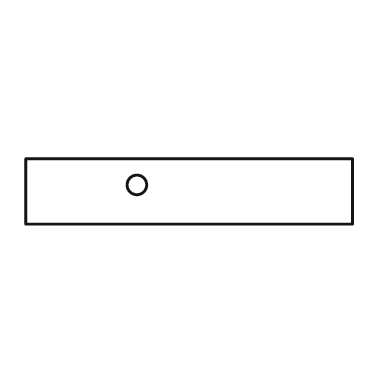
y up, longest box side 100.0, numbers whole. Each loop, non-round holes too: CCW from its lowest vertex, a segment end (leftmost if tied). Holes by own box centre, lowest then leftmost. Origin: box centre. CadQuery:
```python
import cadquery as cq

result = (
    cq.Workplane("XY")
    .moveTo(-50.0, -10.0)
    .lineTo(50.0, -10.0)
    .lineTo(50.0, 10.0)
    .lineTo(-50.0, 10.0)
    .close()
    .moveTo(-16.0, 2.0)
    .circle(3.0)
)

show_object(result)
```